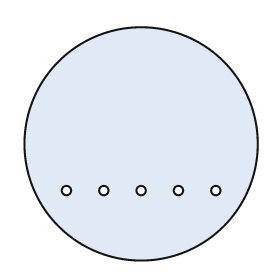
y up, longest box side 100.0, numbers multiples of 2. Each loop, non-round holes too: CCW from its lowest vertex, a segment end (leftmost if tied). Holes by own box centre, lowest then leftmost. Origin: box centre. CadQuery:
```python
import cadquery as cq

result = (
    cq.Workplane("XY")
    .moveTo(0.0, 0.0)
    .circle(50.0)
    .moveTo(-32.0, -20.0)
    .circle(2.0)
    .moveTo(-16.0, -20.0)
    .circle(2.0)
    .moveTo(0.0, -20.0)
    .circle(2.0)
    .moveTo(16.0, -20.0)
    .circle(2.0)
    .moveTo(32.0, -20.0)
    .circle(2.0)
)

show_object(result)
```